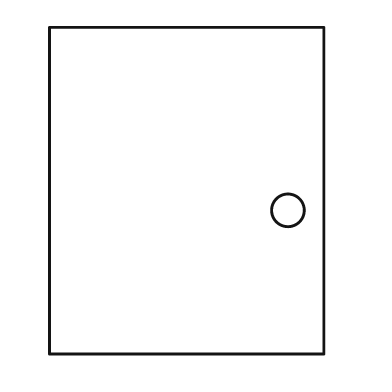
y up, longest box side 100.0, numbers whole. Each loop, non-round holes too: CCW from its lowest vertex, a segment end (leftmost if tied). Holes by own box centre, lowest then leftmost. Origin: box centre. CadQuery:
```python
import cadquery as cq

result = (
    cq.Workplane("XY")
    .moveTo(-42.0, -50.0)
    .lineTo(42.0, -50.0)
    .lineTo(42.0, 50.0)
    .lineTo(-42.0, 50.0)
    .close()
    .moveTo(31.0, -6.0)
    .circle(5.0)
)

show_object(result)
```